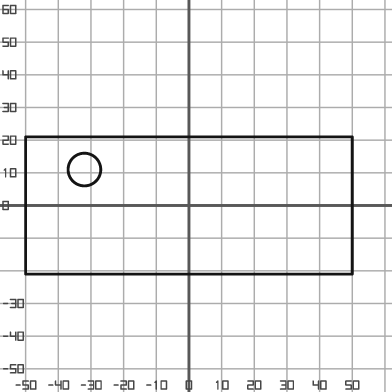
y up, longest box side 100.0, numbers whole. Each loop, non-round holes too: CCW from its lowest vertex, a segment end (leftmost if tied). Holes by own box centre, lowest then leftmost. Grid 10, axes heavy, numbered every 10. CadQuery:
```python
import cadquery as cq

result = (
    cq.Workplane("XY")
    .moveTo(-50.0, -21.0)
    .lineTo(50.0, -21.0)
    .lineTo(50.0, 21.0)
    .lineTo(-50.0, 21.0)
    .close()
    .moveTo(-32.0, 11.0)
    .circle(5.0)
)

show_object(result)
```